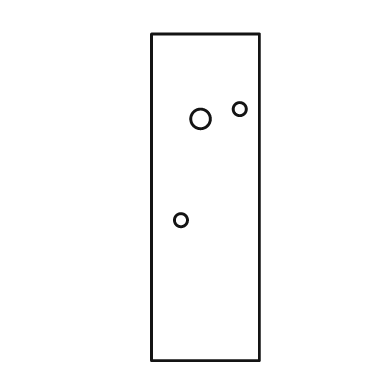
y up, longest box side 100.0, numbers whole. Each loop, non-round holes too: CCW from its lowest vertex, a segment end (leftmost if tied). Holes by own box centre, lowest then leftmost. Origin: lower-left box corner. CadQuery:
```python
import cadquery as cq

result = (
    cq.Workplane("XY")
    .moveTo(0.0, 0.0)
    .lineTo(33.0, 0.0)
    .lineTo(33.0, 100.0)
    .lineTo(0.0, 100.0)
    .close()
    .moveTo(9.0, 43.0)
    .circle(2.0)
    .moveTo(15.0, 74.0)
    .circle(3.0)
    .moveTo(27.0, 77.0)
    .circle(2.0)
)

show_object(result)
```